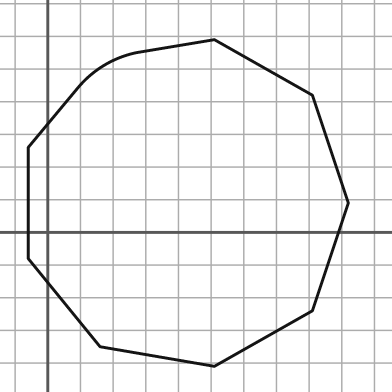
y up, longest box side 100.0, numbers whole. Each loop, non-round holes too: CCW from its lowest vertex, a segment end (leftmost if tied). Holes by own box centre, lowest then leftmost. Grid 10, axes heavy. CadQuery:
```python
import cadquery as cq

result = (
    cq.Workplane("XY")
    .moveTo(51.0, -41.0)
    .lineTo(81.0, -24.0)
    .lineTo(92.0, 9.0)
    .lineTo(81.0, 42.0)
    .lineTo(51.0, 59.0)
    .lineTo(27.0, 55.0)
    .threePointArc((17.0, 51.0), (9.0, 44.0))
    .lineTo(-6.0, 26.0)
    .lineTo(-6.0, -8.0)
    .lineTo(16.0, -35.0)
    .close()
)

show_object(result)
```